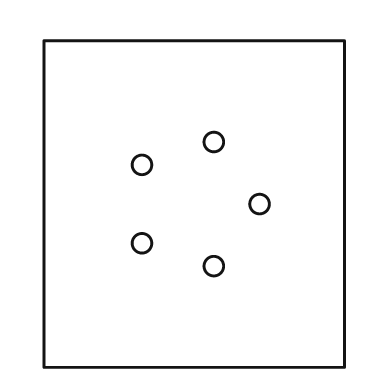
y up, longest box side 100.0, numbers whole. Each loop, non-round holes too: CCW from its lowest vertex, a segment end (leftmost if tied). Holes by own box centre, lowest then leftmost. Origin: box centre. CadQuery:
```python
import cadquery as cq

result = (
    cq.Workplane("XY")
    .moveTo(-46.0, -50.0)
    .lineTo(46.0, -50.0)
    .lineTo(46.0, 50.0)
    .lineTo(-46.0, 50.0)
    .close()
    .moveTo(6.0, -19.0)
    .circle(3.0)
    .moveTo(-16.0, -12.0)
    .circle(3.0)
    .moveTo(20.0, 0.0)
    .circle(3.0)
    .moveTo(-16.0, 12.0)
    .circle(3.0)
    .moveTo(6.0, 19.0)
    .circle(3.0)
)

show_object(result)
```